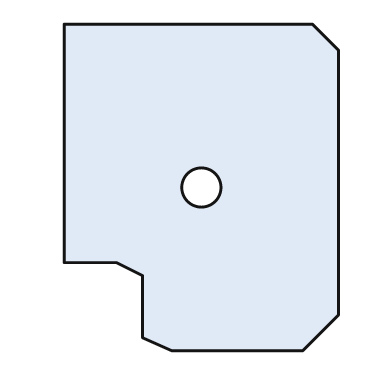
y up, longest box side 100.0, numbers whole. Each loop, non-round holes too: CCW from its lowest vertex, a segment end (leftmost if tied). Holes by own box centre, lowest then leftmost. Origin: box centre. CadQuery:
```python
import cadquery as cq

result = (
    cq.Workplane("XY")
    .moveTo(-9.0, -50.0)
    .lineTo(31.0, -50.0)
    .lineTo(42.0, -39.0)
    .lineTo(42.0, 42.0)
    .lineTo(34.0, 50.0)
    .lineTo(-42.0, 50.0)
    .lineTo(-42.0, -23.0)
    .lineTo(-26.0, -23.0)
    .lineTo(-18.0, -27.0)
    .lineTo(-18.0, -46.0)
    .close()
    .moveTo(0.0, 0.0)
    .circle(6.0)
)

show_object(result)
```